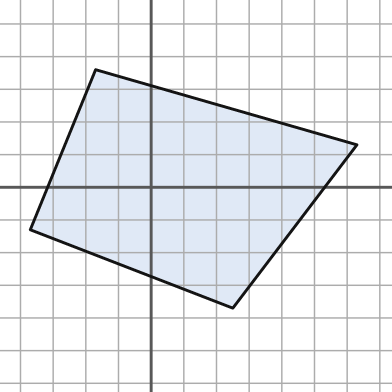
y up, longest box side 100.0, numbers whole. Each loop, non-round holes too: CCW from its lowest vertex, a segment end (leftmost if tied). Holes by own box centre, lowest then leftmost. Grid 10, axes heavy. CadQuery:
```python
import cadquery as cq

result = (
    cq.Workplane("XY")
    .moveTo(25.0, -37.0)
    .lineTo(63.0, 13.0)
    .lineTo(-17.0, 36.0)
    .lineTo(-37.0, -13.0)
    .close()
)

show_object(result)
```